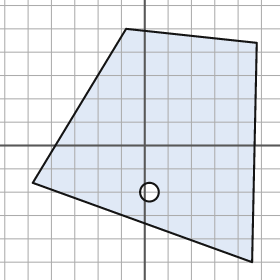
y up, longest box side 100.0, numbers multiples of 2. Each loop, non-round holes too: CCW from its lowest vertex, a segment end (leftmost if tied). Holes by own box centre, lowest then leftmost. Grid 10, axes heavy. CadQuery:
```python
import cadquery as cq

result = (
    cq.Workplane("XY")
    .moveTo(46.0, -50.0)
    .lineTo(48.0, 44.0)
    .lineTo(-8.0, 50.0)
    .lineTo(-48.0, -16.0)
    .close()
    .moveTo(2.0, -20.0)
    .circle(4.0)
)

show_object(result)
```